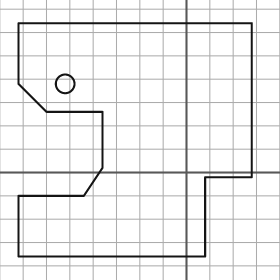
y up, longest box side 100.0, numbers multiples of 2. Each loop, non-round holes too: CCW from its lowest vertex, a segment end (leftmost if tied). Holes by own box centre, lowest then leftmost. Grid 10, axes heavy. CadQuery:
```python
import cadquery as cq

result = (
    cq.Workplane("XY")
    .moveTo(-72.0, -36.0)
    .lineTo(8.0, -36.0)
    .lineTo(8.0, -2.0)
    .lineTo(28.0, -2.0)
    .lineTo(28.0, 64.0)
    .lineTo(-72.0, 64.0)
    .lineTo(-72.0, 38.0)
    .lineTo(-60.0, 26.0)
    .lineTo(-36.0, 26.0)
    .lineTo(-36.0, 2.0)
    .lineTo(-44.0, -10.0)
    .lineTo(-72.0, -10.0)
    .close()
    .moveTo(-52.0, 38.0)
    .circle(4.0)
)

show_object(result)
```